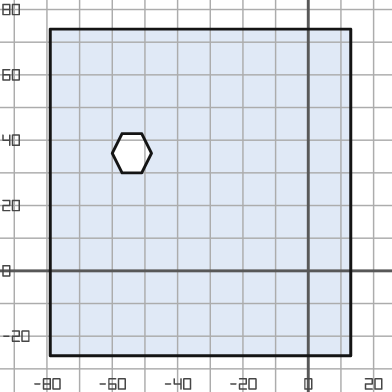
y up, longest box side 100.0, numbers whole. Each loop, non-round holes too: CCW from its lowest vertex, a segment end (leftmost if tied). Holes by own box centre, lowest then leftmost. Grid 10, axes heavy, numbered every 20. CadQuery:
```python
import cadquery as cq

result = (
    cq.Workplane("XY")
    .moveTo(-79.0, -26.0)
    .lineTo(13.0, -26.0)
    .lineTo(13.0, 74.0)
    .lineTo(-79.0, 74.0)
    .close()
    .moveTo(-57.0, 30.0)
    .lineTo(-51.0, 30.0)
    .lineTo(-48.0, 36.0)
    .lineTo(-51.0, 42.0)
    .lineTo(-57.0, 42.0)
    .lineTo(-60.0, 36.0)
    .close()
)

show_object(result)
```